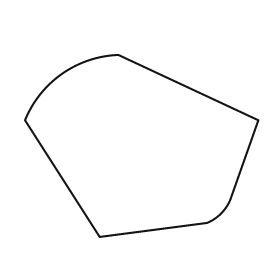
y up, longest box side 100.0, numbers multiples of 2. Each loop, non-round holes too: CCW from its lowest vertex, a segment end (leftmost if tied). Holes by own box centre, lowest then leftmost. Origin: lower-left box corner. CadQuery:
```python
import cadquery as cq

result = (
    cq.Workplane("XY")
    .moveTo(32.0, 0.0)
    .lineTo(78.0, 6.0)
    .threePointArc((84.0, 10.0), (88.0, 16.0))
    .lineTo(100.0, 50.0)
    .lineTo(40.0, 78.0)
    .threePointArc((16.0, 70.0), (0.0, 50.0))
    .close()
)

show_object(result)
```